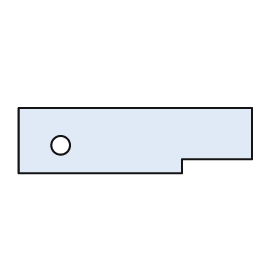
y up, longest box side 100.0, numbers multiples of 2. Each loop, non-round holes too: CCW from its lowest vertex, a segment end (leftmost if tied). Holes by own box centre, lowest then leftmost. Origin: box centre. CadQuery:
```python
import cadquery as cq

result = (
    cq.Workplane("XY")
    .moveTo(-50.0, -14.0)
    .lineTo(20.0, -14.0)
    .lineTo(20.0, -8.0)
    .lineTo(50.0, -8.0)
    .lineTo(50.0, 14.0)
    .lineTo(-50.0, 14.0)
    .close()
    .moveTo(-32.0, -2.0)
    .circle(4.0)
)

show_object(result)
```